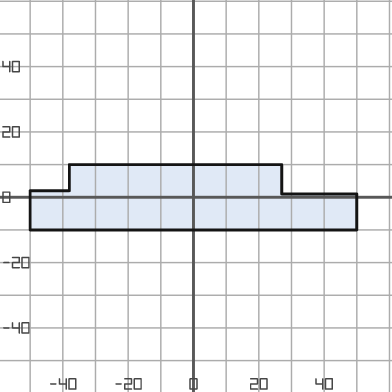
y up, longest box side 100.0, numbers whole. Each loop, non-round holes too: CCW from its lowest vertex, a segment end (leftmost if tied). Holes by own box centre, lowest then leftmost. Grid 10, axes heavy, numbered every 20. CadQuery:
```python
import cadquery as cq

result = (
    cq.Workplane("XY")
    .moveTo(-50.0, -10.0)
    .lineTo(50.0, -10.0)
    .lineTo(50.0, 1.0)
    .lineTo(27.0, 1.0)
    .lineTo(27.0, 10.0)
    .lineTo(-38.0, 10.0)
    .lineTo(-38.0, 2.0)
    .lineTo(-50.0, 2.0)
    .close()
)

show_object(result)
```